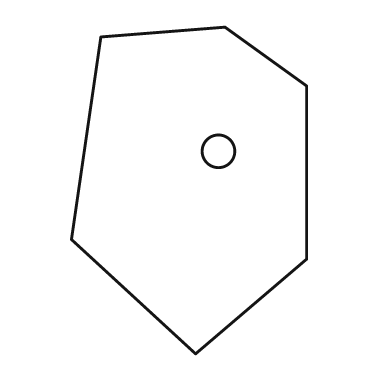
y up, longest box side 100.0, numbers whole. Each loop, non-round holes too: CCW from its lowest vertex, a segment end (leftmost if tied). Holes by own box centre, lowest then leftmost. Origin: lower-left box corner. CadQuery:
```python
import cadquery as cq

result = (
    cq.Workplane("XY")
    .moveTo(38.0, 0.0)
    .lineTo(72.0, 29.0)
    .lineTo(72.0, 82.0)
    .lineTo(47.0, 100.0)
    .lineTo(9.0, 97.0)
    .lineTo(0.0, 35.0)
    .close()
    .moveTo(45.0, 62.0)
    .circle(5.0)
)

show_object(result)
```